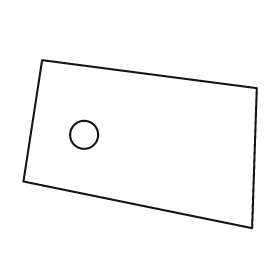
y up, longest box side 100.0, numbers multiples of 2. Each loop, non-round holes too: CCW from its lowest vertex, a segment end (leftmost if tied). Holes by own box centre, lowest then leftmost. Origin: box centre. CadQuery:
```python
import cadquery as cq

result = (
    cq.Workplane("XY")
    .moveTo(48.0, -36.0)
    .lineTo(50.0, 24.0)
    .lineTo(-42.0, 36.0)
    .lineTo(-50.0, -16.0)
    .close()
    .moveTo(-24.0, 4.0)
    .circle(6.0)
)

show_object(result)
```